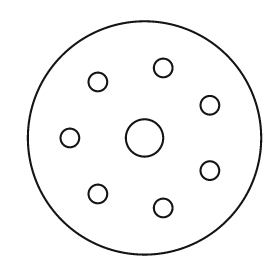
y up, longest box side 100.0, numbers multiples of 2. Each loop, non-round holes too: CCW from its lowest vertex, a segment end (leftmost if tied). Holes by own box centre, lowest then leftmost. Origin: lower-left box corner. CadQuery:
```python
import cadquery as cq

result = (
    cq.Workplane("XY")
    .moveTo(50.0, 50.0)
    .circle(50.0)
    .moveTo(58.0, 20.0)
    .circle(4.0)
    .moveTo(30.0, 26.0)
    .circle(4.0)
    .moveTo(78.0, 36.0)
    .circle(4.0)
    .moveTo(18.0, 50.0)
    .circle(4.0)
    .moveTo(50.0, 50.0)
    .circle(8.0)
    .moveTo(78.0, 64.0)
    .circle(4.0)
    .moveTo(30.0, 74.0)
    .circle(4.0)
    .moveTo(58.0, 80.0)
    .circle(4.0)
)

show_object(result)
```